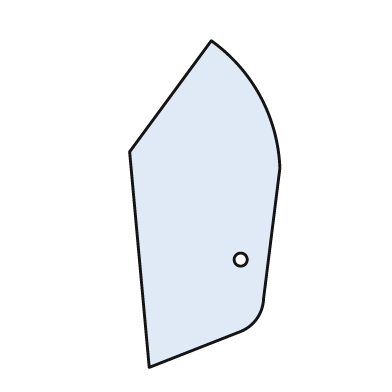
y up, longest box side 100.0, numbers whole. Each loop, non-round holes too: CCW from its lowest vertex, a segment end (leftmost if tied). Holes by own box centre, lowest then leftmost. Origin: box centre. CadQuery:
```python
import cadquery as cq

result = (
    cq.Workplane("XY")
    .moveTo(-17.0, -50.0)
    .lineTo(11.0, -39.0)
    .threePointArc((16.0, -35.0), (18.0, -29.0))
    .lineTo(23.0, 11.0)
    .threePointArc((17.0, 33.0), (2.0, 50.0))
    .lineTo(-23.0, 16.0)
    .close()
    .moveTo(11.0, -17.0)
    .circle(2.0)
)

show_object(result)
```